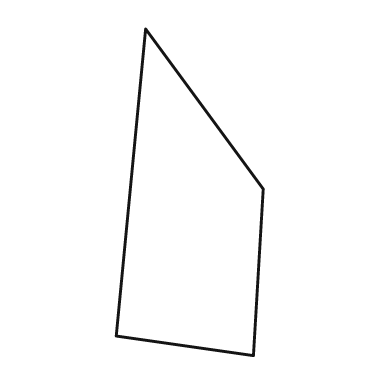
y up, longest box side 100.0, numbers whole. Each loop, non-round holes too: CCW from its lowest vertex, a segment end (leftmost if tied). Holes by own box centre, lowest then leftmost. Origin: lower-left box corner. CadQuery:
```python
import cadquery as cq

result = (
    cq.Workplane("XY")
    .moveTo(42.0, 0.0)
    .lineTo(45.0, 51.0)
    .lineTo(9.0, 100.0)
    .lineTo(0.0, 6.0)
    .close()
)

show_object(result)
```